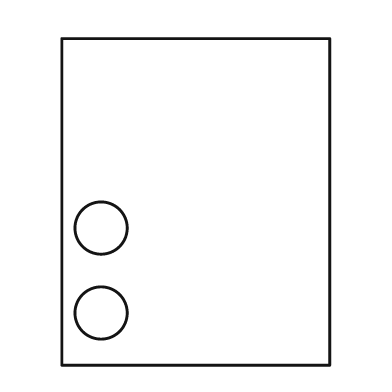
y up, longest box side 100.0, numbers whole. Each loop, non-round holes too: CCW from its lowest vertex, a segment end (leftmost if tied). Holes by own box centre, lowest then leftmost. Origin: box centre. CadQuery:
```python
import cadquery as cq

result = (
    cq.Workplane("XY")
    .moveTo(-41.0, -50.0)
    .lineTo(41.0, -50.0)
    .lineTo(41.0, 50.0)
    .lineTo(-41.0, 50.0)
    .close()
    .moveTo(-29.0, -34.0)
    .circle(8.0)
    .moveTo(-29.0, -8.0)
    .circle(8.0)
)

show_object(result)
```